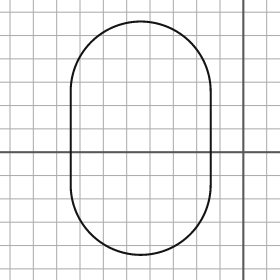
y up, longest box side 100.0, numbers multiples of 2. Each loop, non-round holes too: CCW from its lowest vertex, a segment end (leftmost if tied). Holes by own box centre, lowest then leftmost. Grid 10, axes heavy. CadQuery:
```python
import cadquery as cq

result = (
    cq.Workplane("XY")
    .moveTo(-74.0, -14.0)
    .threePointArc((-44.0, -44.0), (-14.0, -14.0))
    .lineTo(-14.0, 26.0)
    .threePointArc((-44.0, 56.0), (-74.0, 26.0))
    .close()
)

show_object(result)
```